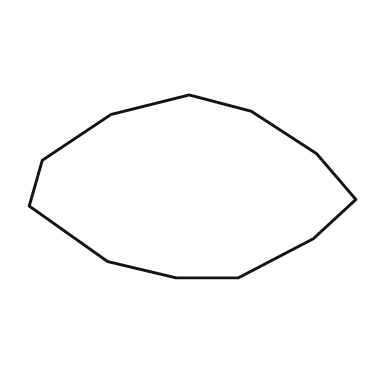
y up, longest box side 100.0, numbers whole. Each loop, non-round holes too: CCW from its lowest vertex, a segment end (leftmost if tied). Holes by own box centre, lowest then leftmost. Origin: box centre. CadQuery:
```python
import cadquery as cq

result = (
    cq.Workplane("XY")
    .moveTo(-5.0, -28.0)
    .lineTo(14.0, -28.0)
    .lineTo(37.0, -16.0)
    .lineTo(50.0, -4.0)
    .lineTo(38.0, 10.0)
    .lineTo(18.0, 23.0)
    .lineTo(-1.0, 28.0)
    .lineTo(-25.0, 22.0)
    .lineTo(-46.0, 8.0)
    .lineTo(-50.0, -6.0)
    .lineTo(-26.0, -23.0)
    .close()
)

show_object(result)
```